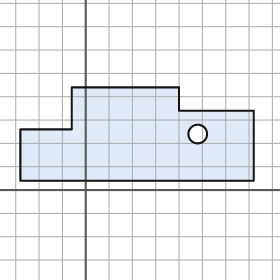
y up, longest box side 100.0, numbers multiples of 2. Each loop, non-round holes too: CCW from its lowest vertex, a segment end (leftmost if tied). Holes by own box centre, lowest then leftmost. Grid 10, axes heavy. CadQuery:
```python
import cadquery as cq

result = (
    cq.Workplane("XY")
    .moveTo(-28.0, 4.0)
    .lineTo(72.0, 4.0)
    .lineTo(72.0, 34.0)
    .lineTo(40.0, 34.0)
    .lineTo(40.0, 44.0)
    .lineTo(-6.0, 44.0)
    .lineTo(-6.0, 26.0)
    .lineTo(-28.0, 26.0)
    .close()
    .moveTo(48.0, 24.0)
    .circle(4.0)
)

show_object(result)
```